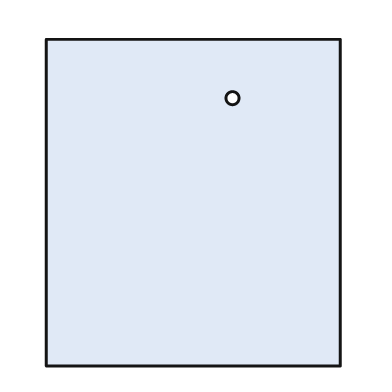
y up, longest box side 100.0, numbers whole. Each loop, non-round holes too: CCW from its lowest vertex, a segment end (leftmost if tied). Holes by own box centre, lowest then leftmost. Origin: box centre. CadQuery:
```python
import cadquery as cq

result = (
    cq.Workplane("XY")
    .moveTo(-45.0, -50.0)
    .lineTo(45.0, -50.0)
    .lineTo(45.0, 50.0)
    .lineTo(-45.0, 50.0)
    .close()
    .moveTo(12.0, 32.0)
    .circle(2.0)
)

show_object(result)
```